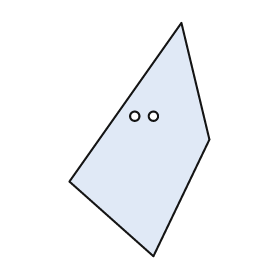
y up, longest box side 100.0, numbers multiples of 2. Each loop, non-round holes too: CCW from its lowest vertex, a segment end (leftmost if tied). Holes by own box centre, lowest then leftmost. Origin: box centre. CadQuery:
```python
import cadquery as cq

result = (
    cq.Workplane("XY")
    .moveTo(6.0, -50.0)
    .lineTo(30.0, 0.0)
    .lineTo(18.0, 50.0)
    .lineTo(-30.0, -18.0)
    .close()
    .moveTo(-2.0, 10.0)
    .circle(2.0)
    .moveTo(6.0, 10.0)
    .circle(2.0)
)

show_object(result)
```